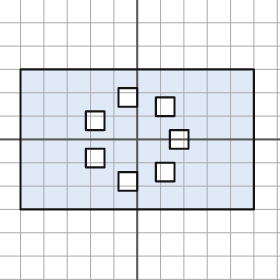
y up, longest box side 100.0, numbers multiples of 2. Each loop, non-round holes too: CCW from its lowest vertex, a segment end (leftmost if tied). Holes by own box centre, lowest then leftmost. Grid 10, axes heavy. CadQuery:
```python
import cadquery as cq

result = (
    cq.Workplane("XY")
    .moveTo(-50.0, -30.0)
    .lineTo(50.0, -30.0)
    .lineTo(50.0, 30.0)
    .lineTo(-50.0, 30.0)
    .close()
    .moveTo(-8.0, -22.0)
    .lineTo(0.0, -22.0)
    .lineTo(0.0, -14.0)
    .lineTo(-8.0, -14.0)
    .close()
    .moveTo(8.0, -18.0)
    .lineTo(16.0, -18.0)
    .lineTo(16.0, -10.0)
    .lineTo(8.0, -10.0)
    .close()
    .moveTo(-22.0, -12.0)
    .lineTo(-14.0, -12.0)
    .lineTo(-14.0, -4.0)
    .lineTo(-22.0, -4.0)
    .close()
    .moveTo(14.0, -4.0)
    .lineTo(22.0, -4.0)
    .lineTo(22.0, 4.0)
    .lineTo(14.0, 4.0)
    .close()
    .moveTo(-22.0, 4.0)
    .lineTo(-14.0, 4.0)
    .lineTo(-14.0, 12.0)
    .lineTo(-22.0, 12.0)
    .close()
    .moveTo(8.0, 10.0)
    .lineTo(16.0, 10.0)
    .lineTo(16.0, 18.0)
    .lineTo(8.0, 18.0)
    .close()
    .moveTo(-8.0, 14.0)
    .lineTo(0.0, 14.0)
    .lineTo(0.0, 22.0)
    .lineTo(-8.0, 22.0)
    .close()
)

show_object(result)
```